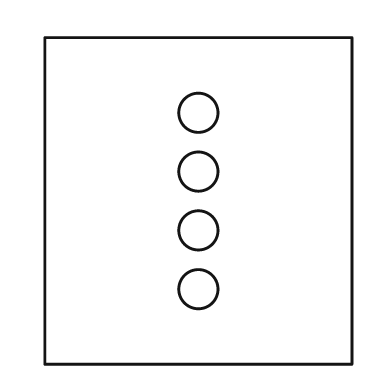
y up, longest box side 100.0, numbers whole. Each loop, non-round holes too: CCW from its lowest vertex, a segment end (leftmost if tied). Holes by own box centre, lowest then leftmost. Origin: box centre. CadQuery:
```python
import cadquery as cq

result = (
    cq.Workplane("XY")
    .moveTo(-47.0, -50.0)
    .lineTo(47.0, -50.0)
    .lineTo(47.0, 50.0)
    .lineTo(-47.0, 50.0)
    .close()
    .moveTo(0.0, -27.0)
    .circle(6.0)
    .moveTo(0.0, -9.0)
    .circle(6.0)
    .moveTo(0.0, 9.0)
    .circle(6.0)
    .moveTo(0.0, 27.0)
    .circle(6.0)
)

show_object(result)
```